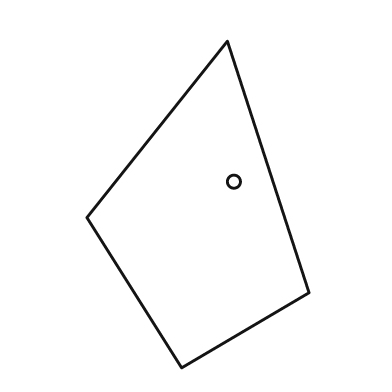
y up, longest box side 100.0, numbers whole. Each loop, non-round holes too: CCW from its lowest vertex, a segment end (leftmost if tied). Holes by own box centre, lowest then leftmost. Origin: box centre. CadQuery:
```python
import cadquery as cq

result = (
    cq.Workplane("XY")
    .moveTo(-5.0, -50.0)
    .lineTo(34.0, -27.0)
    .lineTo(9.0, 50.0)
    .lineTo(-34.0, -4.0)
    .close()
    .moveTo(11.0, 7.0)
    .circle(2.0)
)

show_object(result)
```